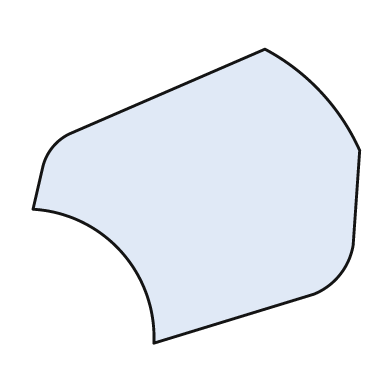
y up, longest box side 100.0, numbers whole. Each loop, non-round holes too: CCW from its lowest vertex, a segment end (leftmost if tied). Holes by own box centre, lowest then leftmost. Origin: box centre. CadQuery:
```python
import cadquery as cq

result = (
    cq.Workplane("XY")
    .moveTo(-13.0, -45.0)
    .lineTo(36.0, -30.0)
    .threePointArc((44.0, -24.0), (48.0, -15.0))
    .lineTo(50.0, 14.0)
    .threePointArc((38.0, 32.0), (21.0, 45.0))
    .lineTo(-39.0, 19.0)
    .threePointArc((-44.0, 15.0), (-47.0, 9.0))
    .lineTo(-50.0, -4.0)
    .threePointArc((-23.0, -17.0), (-13.0, -45.0))
    .close()
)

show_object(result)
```